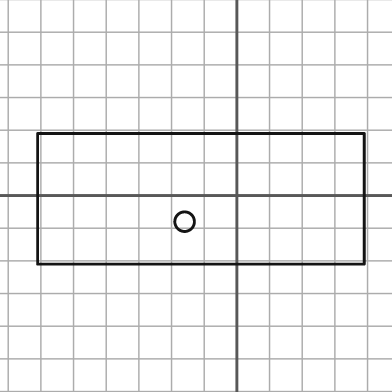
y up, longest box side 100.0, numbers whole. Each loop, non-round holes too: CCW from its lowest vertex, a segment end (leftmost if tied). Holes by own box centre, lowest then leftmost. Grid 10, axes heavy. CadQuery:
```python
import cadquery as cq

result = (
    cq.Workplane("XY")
    .moveTo(-61.0, -21.0)
    .lineTo(39.0, -21.0)
    .lineTo(39.0, 19.0)
    .lineTo(-61.0, 19.0)
    .close()
    .moveTo(-16.0, -8.0)
    .circle(3.0)
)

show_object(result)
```